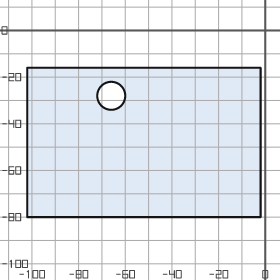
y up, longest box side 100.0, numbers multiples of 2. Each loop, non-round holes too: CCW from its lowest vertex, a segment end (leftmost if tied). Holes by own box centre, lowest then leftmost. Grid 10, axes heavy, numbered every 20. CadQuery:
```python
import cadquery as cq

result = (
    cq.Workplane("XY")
    .moveTo(-102.0, -80.0)
    .lineTo(-2.0, -80.0)
    .lineTo(-2.0, -16.0)
    .lineTo(-102.0, -16.0)
    .close()
    .moveTo(-66.0, -28.0)
    .circle(6.0)
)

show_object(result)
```